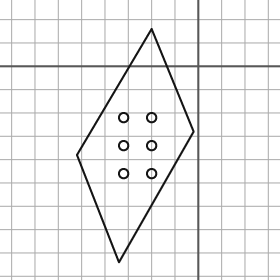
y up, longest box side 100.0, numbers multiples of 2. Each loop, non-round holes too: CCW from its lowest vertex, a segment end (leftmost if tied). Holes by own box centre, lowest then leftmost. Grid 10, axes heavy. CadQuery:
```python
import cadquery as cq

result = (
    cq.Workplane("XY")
    .moveTo(-34.0, -84.0)
    .lineTo(-2.0, -28.0)
    .lineTo(-20.0, 16.0)
    .lineTo(-52.0, -38.0)
    .close()
    .moveTo(-32.0, -46.0)
    .circle(2.0)
    .moveTo(-20.0, -46.0)
    .circle(2.0)
    .moveTo(-32.0, -34.0)
    .circle(2.0)
    .moveTo(-20.0, -34.0)
    .circle(2.0)
    .moveTo(-32.0, -22.0)
    .circle(2.0)
    .moveTo(-20.0, -22.0)
    .circle(2.0)
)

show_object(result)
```